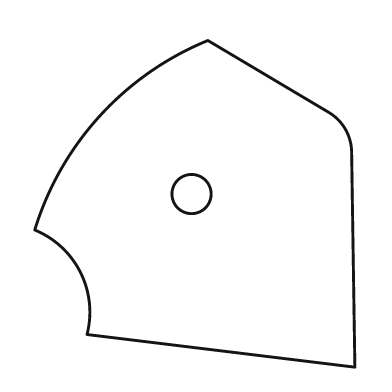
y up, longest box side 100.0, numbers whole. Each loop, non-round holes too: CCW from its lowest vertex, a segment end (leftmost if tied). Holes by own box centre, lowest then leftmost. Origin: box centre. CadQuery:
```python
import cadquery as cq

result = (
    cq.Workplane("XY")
    .moveTo(49.0, -50.0)
    .lineTo(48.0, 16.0)
    .threePointArc((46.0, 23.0), (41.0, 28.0))
    .lineTo(4.0, 50.0)
    .threePointArc((-29.0, 27.0), (-49.0, -8.0))
    .threePointArc((-35.0, -21.0), (-33.0, -40.0))
    .close()
    .moveTo(-1.0, 3.0)
    .circle(6.0)
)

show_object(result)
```